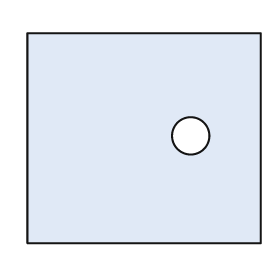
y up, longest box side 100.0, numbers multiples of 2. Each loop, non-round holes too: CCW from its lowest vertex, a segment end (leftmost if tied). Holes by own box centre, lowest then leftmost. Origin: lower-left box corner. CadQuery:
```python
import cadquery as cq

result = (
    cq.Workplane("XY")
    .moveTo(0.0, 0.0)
    .lineTo(100.0, 0.0)
    .lineTo(100.0, 90.0)
    .lineTo(0.0, 90.0)
    .close()
    .moveTo(70.0, 46.0)
    .circle(8.0)
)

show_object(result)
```